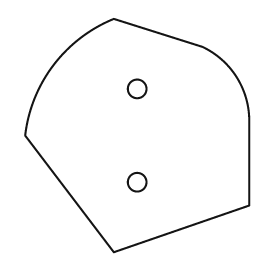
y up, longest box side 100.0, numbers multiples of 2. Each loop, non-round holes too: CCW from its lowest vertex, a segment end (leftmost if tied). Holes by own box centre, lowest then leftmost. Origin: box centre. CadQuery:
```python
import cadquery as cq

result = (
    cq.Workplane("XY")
    .moveTo(-10.0, -50.0)
    .lineTo(48.0, -30.0)
    .lineTo(48.0, 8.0)
    .threePointArc((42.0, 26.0), (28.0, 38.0))
    .lineTo(-10.0, 50.0)
    .threePointArc((-36.0, 30.0), (-48.0, 0.0))
    .close()
    .moveTo(0.0, -20.0)
    .circle(4.0)
    .moveTo(0.0, 20.0)
    .circle(4.0)
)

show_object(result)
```